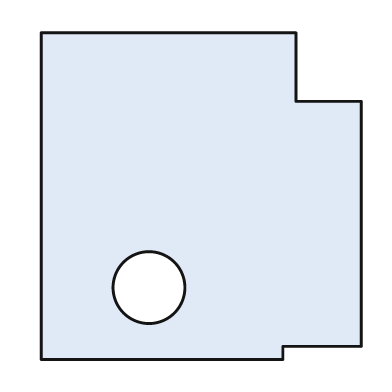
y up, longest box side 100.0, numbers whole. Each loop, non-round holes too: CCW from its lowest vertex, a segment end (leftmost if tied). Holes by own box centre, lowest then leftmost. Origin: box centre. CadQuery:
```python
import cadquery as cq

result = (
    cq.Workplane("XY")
    .moveTo(-49.0, -50.0)
    .lineTo(25.0, -50.0)
    .lineTo(25.0, -46.0)
    .lineTo(49.0, -46.0)
    .lineTo(49.0, 29.0)
    .lineTo(29.0, 29.0)
    .lineTo(29.0, 50.0)
    .lineTo(-49.0, 50.0)
    .close()
    .moveTo(-16.0, -28.0)
    .circle(11.0)
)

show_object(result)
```